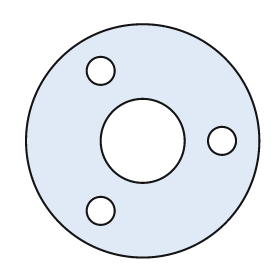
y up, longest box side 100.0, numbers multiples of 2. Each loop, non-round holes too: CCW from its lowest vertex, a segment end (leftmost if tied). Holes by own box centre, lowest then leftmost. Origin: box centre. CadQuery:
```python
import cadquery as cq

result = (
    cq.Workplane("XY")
    .moveTo(0.0, 0.0)
    .circle(50.0)
    .moveTo(-18.0, -30.0)
    .circle(6.0)
    .moveTo(0.0, 0.0)
    .circle(18.0)
    .moveTo(34.0, 0.0)
    .circle(6.0)
    .moveTo(-18.0, 30.0)
    .circle(6.0)
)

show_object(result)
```